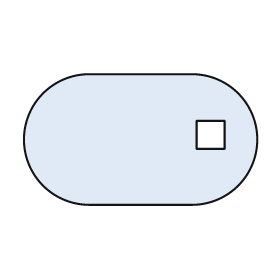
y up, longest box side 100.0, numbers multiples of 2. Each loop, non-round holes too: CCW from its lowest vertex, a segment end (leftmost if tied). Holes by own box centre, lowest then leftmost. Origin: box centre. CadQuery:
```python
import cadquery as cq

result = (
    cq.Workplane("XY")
    .moveTo(-22.0, -28.0)
    .lineTo(22.0, -28.0)
    .threePointArc((50.0, 0.0), (22.0, 28.0))
    .lineTo(-22.0, 28.0)
    .threePointArc((-50.0, 0.0), (-22.0, -28.0))
    .close()
    .moveTo(24.0, -4.0)
    .lineTo(36.0, -4.0)
    .lineTo(36.0, 8.0)
    .lineTo(24.0, 8.0)
    .close()
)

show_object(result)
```